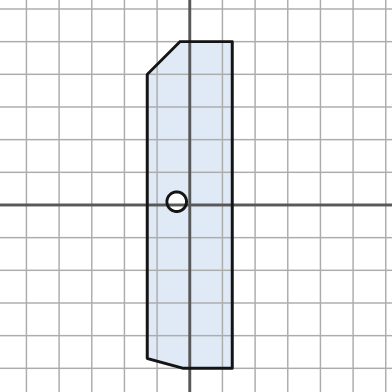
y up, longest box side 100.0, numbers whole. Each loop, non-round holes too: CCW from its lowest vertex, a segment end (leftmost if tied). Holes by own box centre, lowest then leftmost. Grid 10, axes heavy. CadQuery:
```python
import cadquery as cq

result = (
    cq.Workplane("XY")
    .moveTo(-2.0, -50.0)
    .lineTo(13.0, -50.0)
    .lineTo(13.0, 50.0)
    .lineTo(-3.0, 50.0)
    .lineTo(-13.0, 40.0)
    .lineTo(-13.0, -47.0)
    .close()
    .moveTo(-4.0, 1.0)
    .circle(3.0)
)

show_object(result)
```